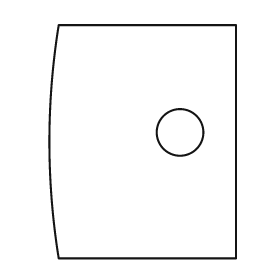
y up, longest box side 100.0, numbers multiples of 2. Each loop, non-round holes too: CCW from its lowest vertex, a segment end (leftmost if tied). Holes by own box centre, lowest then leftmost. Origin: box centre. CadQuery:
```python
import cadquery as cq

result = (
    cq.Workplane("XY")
    .moveTo(-36.0, -50.0)
    .lineTo(40.0, -50.0)
    .lineTo(40.0, 50.0)
    .lineTo(-36.0, 50.0)
    .threePointArc((-40.0, 0.0), (-36.0, -50.0))
    .close()
    .moveTo(16.0, 4.0)
    .circle(10.0)
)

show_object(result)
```